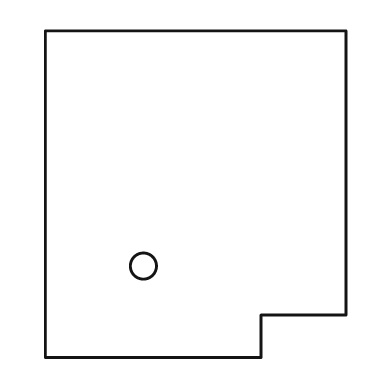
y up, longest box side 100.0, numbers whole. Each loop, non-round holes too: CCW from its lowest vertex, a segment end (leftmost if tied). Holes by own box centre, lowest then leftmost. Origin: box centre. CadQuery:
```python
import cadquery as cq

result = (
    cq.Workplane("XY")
    .moveTo(-46.0, -50.0)
    .lineTo(20.0, -50.0)
    .lineTo(20.0, -37.0)
    .lineTo(46.0, -37.0)
    .lineTo(46.0, 50.0)
    .lineTo(-46.0, 50.0)
    .close()
    .moveTo(-16.0, -22.0)
    .circle(4.0)
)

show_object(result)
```